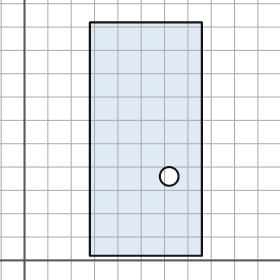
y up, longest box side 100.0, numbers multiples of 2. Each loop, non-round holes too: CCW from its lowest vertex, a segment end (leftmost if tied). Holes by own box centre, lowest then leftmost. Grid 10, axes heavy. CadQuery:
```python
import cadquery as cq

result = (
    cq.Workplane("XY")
    .moveTo(28.0, 2.0)
    .lineTo(76.0, 2.0)
    .lineTo(76.0, 102.0)
    .lineTo(28.0, 102.0)
    .close()
    .moveTo(62.0, 36.0)
    .circle(4.0)
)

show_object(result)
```